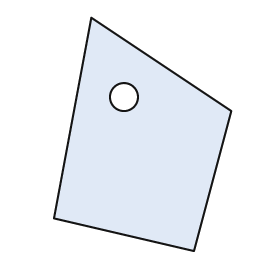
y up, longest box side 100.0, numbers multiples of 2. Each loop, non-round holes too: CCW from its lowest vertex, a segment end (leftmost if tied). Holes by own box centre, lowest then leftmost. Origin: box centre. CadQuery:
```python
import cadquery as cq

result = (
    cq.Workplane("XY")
    .moveTo(22.0, -50.0)
    .lineTo(38.0, 10.0)
    .lineTo(-22.0, 50.0)
    .lineTo(-38.0, -36.0)
    .close()
    .moveTo(-8.0, 16.0)
    .circle(6.0)
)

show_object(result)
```